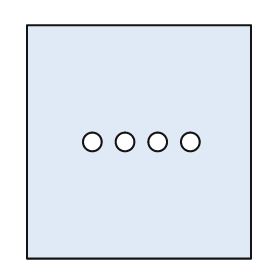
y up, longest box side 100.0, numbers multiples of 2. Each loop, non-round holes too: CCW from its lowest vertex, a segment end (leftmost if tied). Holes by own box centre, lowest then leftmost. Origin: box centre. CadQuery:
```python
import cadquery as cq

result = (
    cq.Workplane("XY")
    .moveTo(-48.0, -50.0)
    .lineTo(48.0, -50.0)
    .lineTo(48.0, 50.0)
    .lineTo(-48.0, 50.0)
    .close()
    .moveTo(-20.0, 0.0)
    .circle(4.0)
    .moveTo(-6.0, 0.0)
    .circle(4.0)
    .moveTo(8.0, 0.0)
    .circle(4.0)
    .moveTo(22.0, 0.0)
    .circle(4.0)
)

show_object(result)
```